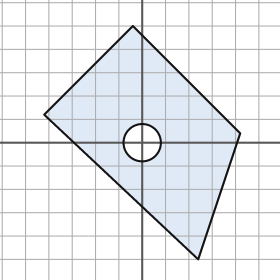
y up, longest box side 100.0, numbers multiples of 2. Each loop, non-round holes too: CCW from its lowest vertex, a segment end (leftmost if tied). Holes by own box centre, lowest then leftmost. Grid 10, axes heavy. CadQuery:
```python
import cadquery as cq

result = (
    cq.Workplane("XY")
    .moveTo(24.0, -50.0)
    .lineTo(42.0, 4.0)
    .lineTo(-4.0, 50.0)
    .lineTo(-42.0, 12.0)
    .close()
    .moveTo(0.0, 0.0)
    .circle(8.0)
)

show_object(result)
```